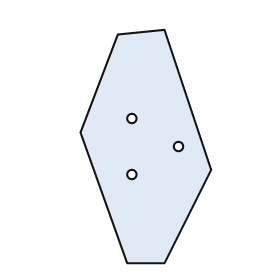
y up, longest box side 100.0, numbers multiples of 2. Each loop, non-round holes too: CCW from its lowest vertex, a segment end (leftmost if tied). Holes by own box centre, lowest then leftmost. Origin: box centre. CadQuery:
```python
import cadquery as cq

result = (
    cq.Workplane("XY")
    .moveTo(-8.0, -50.0)
    .lineTo(8.0, -50.0)
    .lineTo(28.0, -10.0)
    .lineTo(8.0, 50.0)
    .lineTo(-12.0, 48.0)
    .lineTo(-28.0, 6.0)
    .close()
    .moveTo(-6.0, -12.0)
    .circle(2.0)
    .moveTo(14.0, 0.0)
    .circle(2.0)
    .moveTo(-6.0, 12.0)
    .circle(2.0)
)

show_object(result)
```